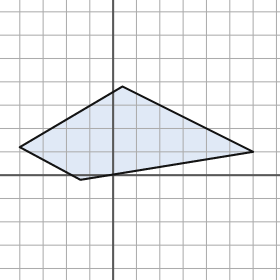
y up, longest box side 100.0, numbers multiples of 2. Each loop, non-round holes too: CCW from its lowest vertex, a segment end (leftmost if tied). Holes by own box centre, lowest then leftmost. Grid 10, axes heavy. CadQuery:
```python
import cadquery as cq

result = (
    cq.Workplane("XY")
    .moveTo(-14.0, -2.0)
    .lineTo(60.0, 10.0)
    .lineTo(4.0, 38.0)
    .lineTo(-40.0, 12.0)
    .close()
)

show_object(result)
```